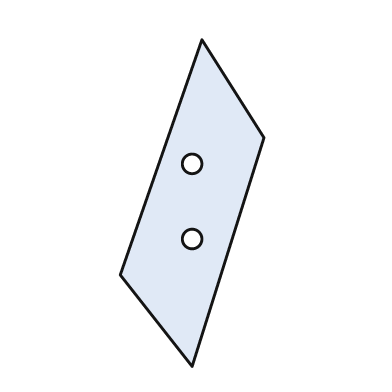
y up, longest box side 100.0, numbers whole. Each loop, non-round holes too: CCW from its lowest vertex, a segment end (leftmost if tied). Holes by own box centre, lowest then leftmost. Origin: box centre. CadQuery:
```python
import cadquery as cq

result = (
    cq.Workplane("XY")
    .moveTo(0.0, -50.0)
    .lineTo(22.0, 20.0)
    .lineTo(3.0, 50.0)
    .lineTo(-22.0, -22.0)
    .close()
    .moveTo(0.0, -11.0)
    .circle(3.0)
    .moveTo(0.0, 12.0)
    .circle(3.0)
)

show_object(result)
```